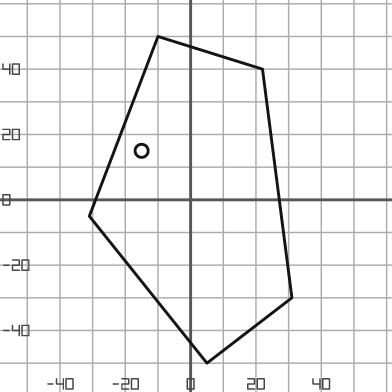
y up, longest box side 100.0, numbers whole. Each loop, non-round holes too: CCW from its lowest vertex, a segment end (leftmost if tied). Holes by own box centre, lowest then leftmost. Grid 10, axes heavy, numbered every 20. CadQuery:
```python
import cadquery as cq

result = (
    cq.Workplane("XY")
    .moveTo(5.0, -50.0)
    .lineTo(31.0, -30.0)
    .lineTo(22.0, 40.0)
    .lineTo(-10.0, 50.0)
    .lineTo(-31.0, -5.0)
    .close()
    .moveTo(-15.0, 15.0)
    .circle(2.0)
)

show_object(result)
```